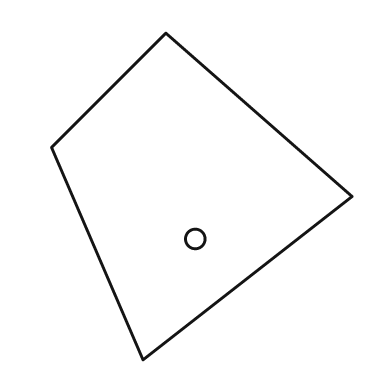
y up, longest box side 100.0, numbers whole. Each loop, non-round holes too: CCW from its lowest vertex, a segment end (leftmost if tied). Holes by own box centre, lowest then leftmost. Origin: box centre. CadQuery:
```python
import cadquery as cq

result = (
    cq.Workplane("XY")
    .moveTo(-18.0, -50.0)
    .lineTo(46.0, 0.0)
    .lineTo(-11.0, 50.0)
    .lineTo(-46.0, 15.0)
    .close()
    .moveTo(-2.0, -13.0)
    .circle(3.0)
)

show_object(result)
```